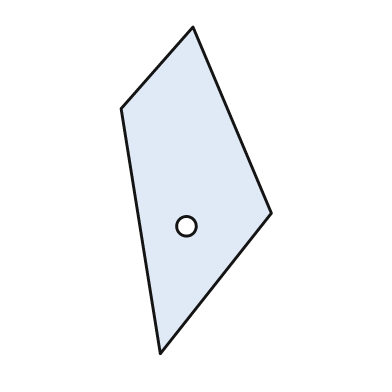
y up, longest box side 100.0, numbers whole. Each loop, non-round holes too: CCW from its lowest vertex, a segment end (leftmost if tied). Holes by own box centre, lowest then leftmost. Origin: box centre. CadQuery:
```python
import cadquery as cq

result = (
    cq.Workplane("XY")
    .moveTo(-11.0, -50.0)
    .lineTo(23.0, -7.0)
    .lineTo(-1.0, 50.0)
    .lineTo(-23.0, 25.0)
    .close()
    .moveTo(-3.0, -11.0)
    .circle(3.0)
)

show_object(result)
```